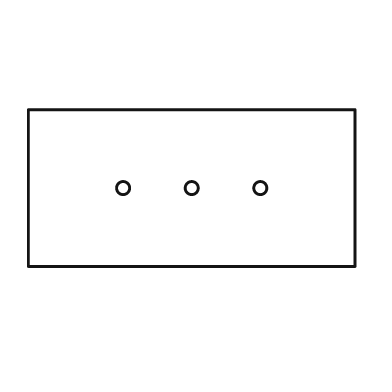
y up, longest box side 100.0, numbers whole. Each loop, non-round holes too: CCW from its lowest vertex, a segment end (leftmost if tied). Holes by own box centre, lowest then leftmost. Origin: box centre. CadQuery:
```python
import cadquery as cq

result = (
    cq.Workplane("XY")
    .moveTo(-50.0, -24.0)
    .lineTo(50.0, -24.0)
    .lineTo(50.0, 24.0)
    .lineTo(-50.0, 24.0)
    .close()
    .moveTo(-21.0, 0.0)
    .circle(2.0)
    .moveTo(0.0, 0.0)
    .circle(2.0)
    .moveTo(21.0, 0.0)
    .circle(2.0)
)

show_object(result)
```